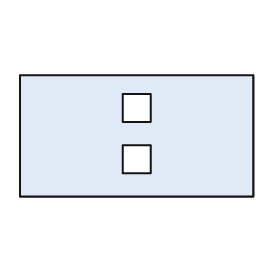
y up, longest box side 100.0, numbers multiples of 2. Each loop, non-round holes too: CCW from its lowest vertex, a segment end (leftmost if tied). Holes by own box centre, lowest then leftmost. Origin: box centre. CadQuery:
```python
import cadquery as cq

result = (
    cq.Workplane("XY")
    .moveTo(-50.0, -26.0)
    .lineTo(50.0, -26.0)
    .lineTo(50.0, 26.0)
    .lineTo(-50.0, 26.0)
    .close()
    .moveTo(-6.0, -16.0)
    .lineTo(6.0, -16.0)
    .lineTo(6.0, -4.0)
    .lineTo(-6.0, -4.0)
    .close()
    .moveTo(-6.0, 6.0)
    .lineTo(6.0, 6.0)
    .lineTo(6.0, 18.0)
    .lineTo(-6.0, 18.0)
    .close()
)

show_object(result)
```